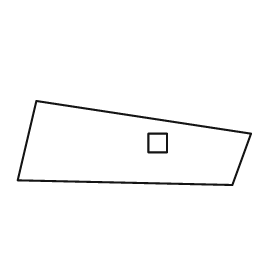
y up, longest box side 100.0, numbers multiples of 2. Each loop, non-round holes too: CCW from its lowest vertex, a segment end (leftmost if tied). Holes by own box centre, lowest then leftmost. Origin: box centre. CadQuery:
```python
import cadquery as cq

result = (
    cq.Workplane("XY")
    .moveTo(42.0, -18.0)
    .lineTo(50.0, 4.0)
    .lineTo(-42.0, 18.0)
    .lineTo(-50.0, -16.0)
    .close()
    .moveTo(6.0, -4.0)
    .lineTo(14.0, -4.0)
    .lineTo(14.0, 4.0)
    .lineTo(6.0, 4.0)
    .close()
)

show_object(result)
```